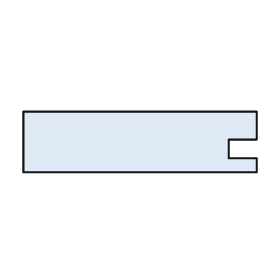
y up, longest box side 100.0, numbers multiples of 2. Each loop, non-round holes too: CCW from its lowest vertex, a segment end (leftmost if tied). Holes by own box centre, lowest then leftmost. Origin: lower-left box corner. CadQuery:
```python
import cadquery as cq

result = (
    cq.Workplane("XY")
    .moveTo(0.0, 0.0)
    .lineTo(100.0, 0.0)
    .lineTo(100.0, 6.0)
    .lineTo(88.0, 6.0)
    .lineTo(88.0, 14.0)
    .lineTo(100.0, 14.0)
    .lineTo(100.0, 26.0)
    .lineTo(0.0, 26.0)
    .close()
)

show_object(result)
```